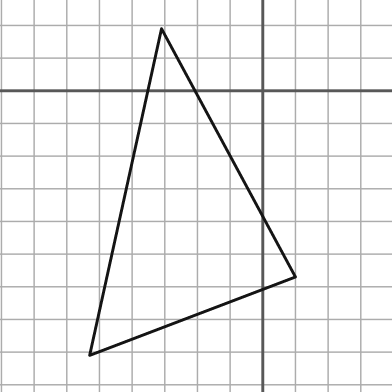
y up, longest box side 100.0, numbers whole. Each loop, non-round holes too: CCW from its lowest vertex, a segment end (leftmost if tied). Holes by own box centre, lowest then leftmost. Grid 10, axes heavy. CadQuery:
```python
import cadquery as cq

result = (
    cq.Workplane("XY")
    .moveTo(-53.0, -81.0)
    .lineTo(10.0, -57.0)
    .lineTo(-31.0, 19.0)
    .close()
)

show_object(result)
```